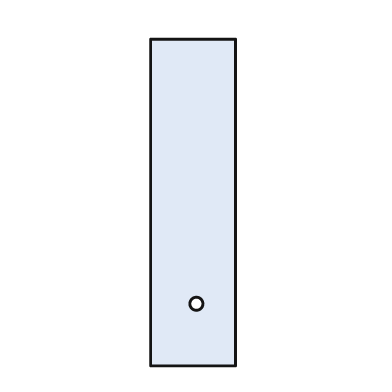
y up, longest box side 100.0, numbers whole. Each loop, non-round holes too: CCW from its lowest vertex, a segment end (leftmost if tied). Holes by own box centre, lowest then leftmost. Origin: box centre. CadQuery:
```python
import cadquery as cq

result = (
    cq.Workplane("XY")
    .moveTo(-13.0, -50.0)
    .lineTo(13.0, -50.0)
    .lineTo(13.0, 50.0)
    .lineTo(-13.0, 50.0)
    .close()
    .moveTo(1.0, -31.0)
    .circle(2.0)
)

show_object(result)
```